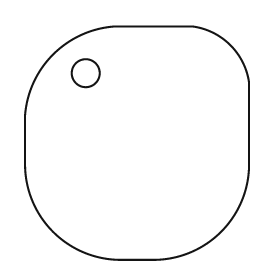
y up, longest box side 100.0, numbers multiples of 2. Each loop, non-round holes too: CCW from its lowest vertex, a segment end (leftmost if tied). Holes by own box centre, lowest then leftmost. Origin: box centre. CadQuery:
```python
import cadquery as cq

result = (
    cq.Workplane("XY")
    .moveTo(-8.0, -50.0)
    .lineTo(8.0, -50.0)
    .threePointArc((36.0, -38.0), (48.0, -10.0))
    .lineTo(48.0, 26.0)
    .threePointArc((40.0, 42.0), (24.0, 50.0))
    .lineTo(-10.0, 50.0)
    .threePointArc((-36.0, 38.0), (-48.0, 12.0))
    .lineTo(-48.0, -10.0)
    .threePointArc((-36.0, -38.0), (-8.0, -50.0))
    .close()
    .moveTo(-22.0, 30.0)
    .circle(6.0)
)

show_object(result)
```